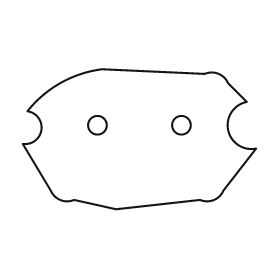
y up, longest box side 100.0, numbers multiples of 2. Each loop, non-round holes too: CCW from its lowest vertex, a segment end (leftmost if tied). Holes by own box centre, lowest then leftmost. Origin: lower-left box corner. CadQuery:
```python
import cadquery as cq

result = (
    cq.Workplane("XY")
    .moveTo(40.0, 0.0)
    .lineTo(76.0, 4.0)
    .threePointArc((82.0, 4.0), (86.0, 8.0))
    .lineTo(100.0, 26.0)
    .threePointArc((88.0, 34.0), (96.0, 46.0))
    .lineTo(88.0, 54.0)
    .threePointArc((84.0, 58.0), (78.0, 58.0))
    .lineTo(34.0, 60.0)
    .threePointArc((16.0, 54.0), (2.0, 42.0))
    .threePointArc((8.0, 34.0), (0.0, 28.0))
    .lineTo(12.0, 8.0)
    .threePointArc((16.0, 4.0), (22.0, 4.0))
    .close()
    .moveTo(32.0, 36.0)
    .circle(4.0)
    .moveTo(68.0, 36.0)
    .circle(4.0)
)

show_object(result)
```